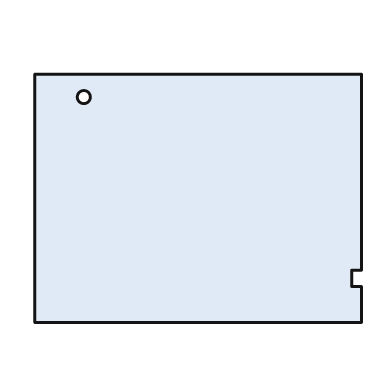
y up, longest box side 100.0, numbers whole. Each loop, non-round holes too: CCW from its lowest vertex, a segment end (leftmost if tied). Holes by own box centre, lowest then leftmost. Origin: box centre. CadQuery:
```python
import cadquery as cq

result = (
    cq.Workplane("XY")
    .moveTo(-50.0, -38.0)
    .lineTo(50.0, -38.0)
    .lineTo(50.0, -27.0)
    .lineTo(47.0, -27.0)
    .lineTo(47.0, -22.0)
    .lineTo(50.0, -22.0)
    .lineTo(50.0, 38.0)
    .lineTo(-50.0, 38.0)
    .close()
    .moveTo(-35.0, 31.0)
    .circle(2.0)
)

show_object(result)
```